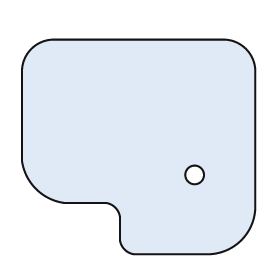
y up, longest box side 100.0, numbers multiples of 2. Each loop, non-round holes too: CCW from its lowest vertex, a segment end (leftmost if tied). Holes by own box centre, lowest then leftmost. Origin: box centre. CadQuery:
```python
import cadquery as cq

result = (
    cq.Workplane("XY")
    .moveTo(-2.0, -46.0)
    .lineTo(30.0, -46.0)
    .threePointArc((44.0, -40.0), (50.0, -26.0))
    .lineTo(50.0, 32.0)
    .threePointArc((46.0, 42.0), (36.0, 46.0))
    .lineTo(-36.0, 46.0)
    .threePointArc((-46.0, 42.0), (-50.0, 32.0))
    .lineTo(-50.0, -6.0)
    .threePointArc((-44.0, -18.0), (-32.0, -24.0))
    .lineTo(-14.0, -24.0)
    .threePointArc((-10.0, -26.0), (-8.0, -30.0))
    .lineTo(-8.0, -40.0)
    .threePointArc((-6.0, -44.0), (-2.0, -46.0))
    .close()
    .moveTo(24.0, -12.0)
    .circle(4.0)
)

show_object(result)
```